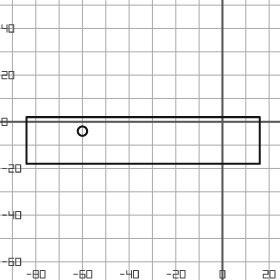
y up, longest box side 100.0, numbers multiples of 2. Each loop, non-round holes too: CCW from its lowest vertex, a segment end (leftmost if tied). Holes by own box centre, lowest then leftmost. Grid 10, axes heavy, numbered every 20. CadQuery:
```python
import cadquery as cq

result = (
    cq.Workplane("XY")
    .moveTo(-84.0, -18.0)
    .lineTo(16.0, -18.0)
    .lineTo(16.0, 2.0)
    .lineTo(-84.0, 2.0)
    .close()
    .moveTo(-60.0, -4.0)
    .circle(2.0)
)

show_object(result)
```